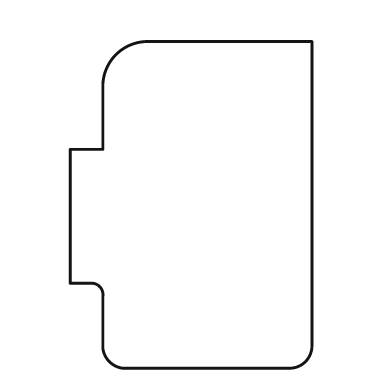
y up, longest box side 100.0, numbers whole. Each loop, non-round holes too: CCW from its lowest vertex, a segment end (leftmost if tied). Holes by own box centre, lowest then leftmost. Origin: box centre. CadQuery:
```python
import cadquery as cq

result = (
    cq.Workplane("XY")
    .moveTo(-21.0, -50.0)
    .lineTo(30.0, -50.0)
    .threePointArc((35.0, -48.0), (37.0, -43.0))
    .lineTo(37.0, 50.0)
    .lineTo(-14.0, 50.0)
    .threePointArc((-23.0, 46.0), (-27.0, 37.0))
    .lineTo(-27.0, 17.0)
    .lineTo(-37.0, 17.0)
    .lineTo(-37.0, -24.0)
    .lineTo(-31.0, -24.0)
    .threePointArc((-28.0, -25.0), (-27.0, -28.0))
    .lineTo(-27.0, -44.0)
    .threePointArc((-25.0, -48.0), (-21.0, -50.0))
    .close()
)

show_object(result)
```